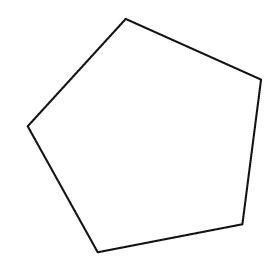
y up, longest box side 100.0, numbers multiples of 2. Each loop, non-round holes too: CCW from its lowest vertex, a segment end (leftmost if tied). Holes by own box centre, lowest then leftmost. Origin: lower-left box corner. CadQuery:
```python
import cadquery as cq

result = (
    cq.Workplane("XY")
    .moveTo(30.0, 0.0)
    .lineTo(92.0, 12.0)
    .lineTo(100.0, 74.0)
    .lineTo(42.0, 100.0)
    .lineTo(0.0, 54.0)
    .close()
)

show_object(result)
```